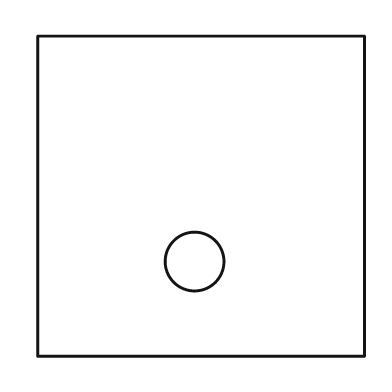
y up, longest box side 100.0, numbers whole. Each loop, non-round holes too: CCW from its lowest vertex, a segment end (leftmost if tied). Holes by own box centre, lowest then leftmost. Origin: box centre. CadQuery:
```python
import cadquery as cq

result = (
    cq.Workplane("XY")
    .moveTo(-50.0, -49.0)
    .lineTo(50.0, -49.0)
    .lineTo(50.0, 49.0)
    .lineTo(-50.0, 49.0)
    .close()
    .moveTo(-2.0, -20.0)
    .circle(9.0)
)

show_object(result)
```